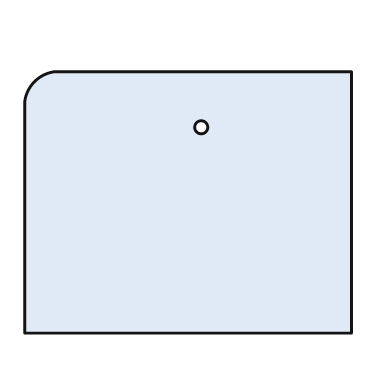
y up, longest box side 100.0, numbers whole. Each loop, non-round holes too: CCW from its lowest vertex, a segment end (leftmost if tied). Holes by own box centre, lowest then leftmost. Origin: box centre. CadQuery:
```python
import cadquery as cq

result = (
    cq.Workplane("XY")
    .moveTo(-50.0, -40.0)
    .lineTo(50.0, -40.0)
    .lineTo(50.0, 40.0)
    .lineTo(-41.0, 40.0)
    .threePointArc((-47.0, 37.0), (-50.0, 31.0))
    .close()
    .moveTo(4.0, 23.0)
    .circle(2.0)
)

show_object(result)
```